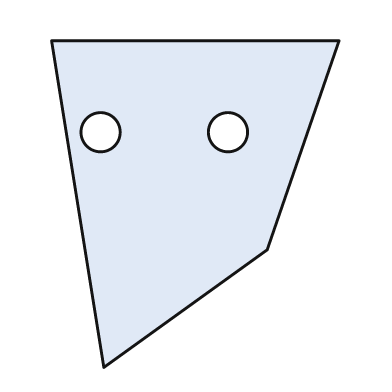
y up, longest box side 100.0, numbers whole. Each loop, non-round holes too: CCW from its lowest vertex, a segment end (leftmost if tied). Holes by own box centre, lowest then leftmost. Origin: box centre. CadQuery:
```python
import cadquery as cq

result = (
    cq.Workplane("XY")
    .moveTo(-28.0, -50.0)
    .lineTo(22.0, -14.0)
    .lineTo(44.0, 50.0)
    .lineTo(-44.0, 50.0)
    .close()
    .moveTo(-29.0, 22.0)
    .circle(6.0)
    .moveTo(10.0, 22.0)
    .circle(6.0)
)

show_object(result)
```